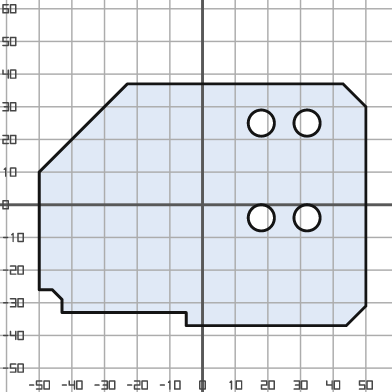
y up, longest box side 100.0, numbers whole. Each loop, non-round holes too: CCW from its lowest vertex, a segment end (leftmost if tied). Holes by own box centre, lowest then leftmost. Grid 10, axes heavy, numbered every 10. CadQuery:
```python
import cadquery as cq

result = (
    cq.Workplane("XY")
    .moveTo(-5.0, -37.0)
    .lineTo(44.0, -37.0)
    .lineTo(50.0, -31.0)
    .lineTo(50.0, 30.0)
    .lineTo(43.0, 37.0)
    .lineTo(-23.0, 37.0)
    .lineTo(-50.0, 10.0)
    .lineTo(-50.0, -26.0)
    .lineTo(-46.0, -26.0)
    .lineTo(-43.0, -29.0)
    .lineTo(-43.0, -33.0)
    .lineTo(-5.0, -33.0)
    .close()
    .moveTo(18.0, -4.0)
    .circle(4.0)
    .moveTo(32.0, -4.0)
    .circle(4.0)
    .moveTo(18.0, 25.0)
    .circle(4.0)
    .moveTo(32.0, 25.0)
    .circle(4.0)
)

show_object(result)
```